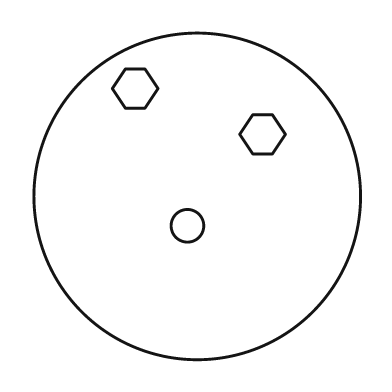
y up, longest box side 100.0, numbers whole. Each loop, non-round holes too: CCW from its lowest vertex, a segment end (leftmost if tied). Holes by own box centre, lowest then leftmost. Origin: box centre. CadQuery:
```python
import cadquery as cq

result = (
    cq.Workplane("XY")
    .moveTo(0.0, 0.0)
    .circle(50.0)
    .moveTo(-3.0, -9.0)
    .circle(5.0)
    .moveTo(17.0, 13.0)
    .lineTo(23.0, 13.0)
    .lineTo(27.0, 19.0)
    .lineTo(23.0, 25.0)
    .lineTo(17.0, 25.0)
    .lineTo(13.0, 19.0)
    .close()
    .moveTo(-22.0, 27.0)
    .lineTo(-16.0, 27.0)
    .lineTo(-12.0, 33.0)
    .lineTo(-16.0, 39.0)
    .lineTo(-22.0, 39.0)
    .lineTo(-26.0, 33.0)
    .close()
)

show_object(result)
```